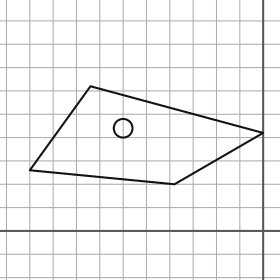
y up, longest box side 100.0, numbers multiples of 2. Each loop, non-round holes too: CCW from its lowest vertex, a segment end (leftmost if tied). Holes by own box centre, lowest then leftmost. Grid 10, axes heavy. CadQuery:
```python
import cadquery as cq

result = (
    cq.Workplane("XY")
    .moveTo(-38.0, 20.0)
    .lineTo(0.0, 42.0)
    .lineTo(-74.0, 62.0)
    .lineTo(-100.0, 26.0)
    .close()
    .moveTo(-60.0, 44.0)
    .circle(4.0)
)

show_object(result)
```